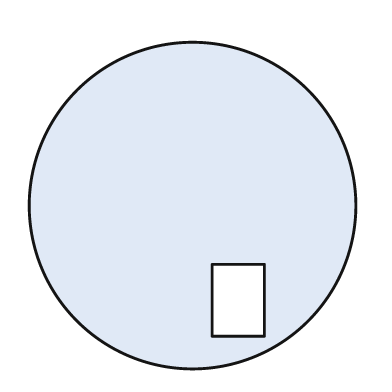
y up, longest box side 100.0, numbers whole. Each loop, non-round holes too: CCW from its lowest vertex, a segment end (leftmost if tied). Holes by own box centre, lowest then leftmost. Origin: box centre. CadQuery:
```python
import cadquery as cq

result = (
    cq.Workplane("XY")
    .moveTo(0.0, 0.0)
    .circle(50.0)
    .moveTo(6.0, -40.0)
    .lineTo(22.0, -40.0)
    .lineTo(22.0, -18.0)
    .lineTo(6.0, -18.0)
    .close()
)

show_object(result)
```